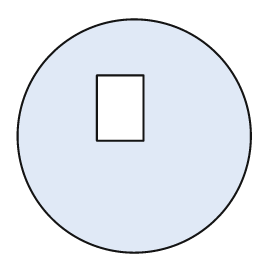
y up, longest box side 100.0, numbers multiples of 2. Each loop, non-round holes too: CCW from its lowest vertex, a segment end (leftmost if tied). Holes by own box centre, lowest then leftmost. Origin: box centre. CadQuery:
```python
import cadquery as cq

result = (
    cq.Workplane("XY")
    .moveTo(0.0, 0.0)
    .circle(50.0)
    .moveTo(-16.0, -2.0)
    .lineTo(4.0, -2.0)
    .lineTo(4.0, 26.0)
    .lineTo(-16.0, 26.0)
    .close()
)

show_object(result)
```